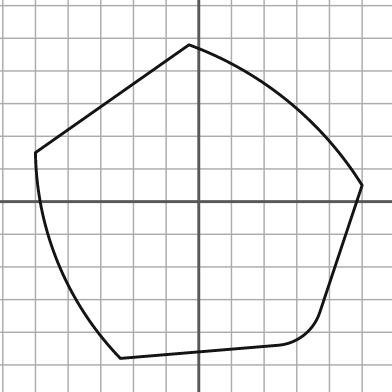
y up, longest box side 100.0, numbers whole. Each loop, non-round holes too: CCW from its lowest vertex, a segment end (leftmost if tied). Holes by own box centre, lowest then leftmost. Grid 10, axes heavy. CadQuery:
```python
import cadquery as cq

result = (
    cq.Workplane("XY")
    .moveTo(-24.0, -48.0)
    .lineTo(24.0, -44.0)
    .threePointArc((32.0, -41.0), (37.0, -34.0))
    .lineTo(50.0, 5.0)
    .threePointArc((27.0, 31.0), (-3.0, 48.0))
    .lineTo(-50.0, 15.0)
    .threePointArc((-43.0, -19.0), (-24.0, -48.0))
    .close()
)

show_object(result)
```